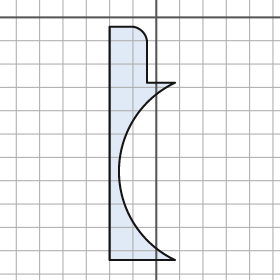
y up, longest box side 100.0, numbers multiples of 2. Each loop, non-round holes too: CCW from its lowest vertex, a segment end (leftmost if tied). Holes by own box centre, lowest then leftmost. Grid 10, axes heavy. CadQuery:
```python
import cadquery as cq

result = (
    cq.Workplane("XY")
    .moveTo(-20.0, -104.0)
    .lineTo(8.0, -104.0)
    .threePointArc((-16.0, -66.0), (8.0, -28.0))
    .lineTo(-4.0, -28.0)
    .lineTo(-4.0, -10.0)
    .threePointArc((-6.0, -6.0), (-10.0, -4.0))
    .lineTo(-20.0, -4.0)
    .close()
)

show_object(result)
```